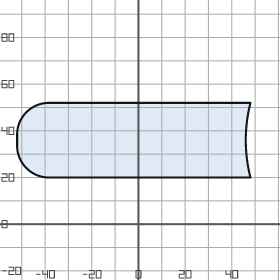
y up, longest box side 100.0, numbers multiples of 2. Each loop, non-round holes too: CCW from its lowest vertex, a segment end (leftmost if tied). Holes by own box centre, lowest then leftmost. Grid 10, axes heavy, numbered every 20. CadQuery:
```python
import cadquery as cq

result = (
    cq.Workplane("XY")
    .moveTo(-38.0, 20.0)
    .lineTo(48.0, 20.0)
    .threePointArc((46.0, 36.0), (48.0, 52.0))
    .lineTo(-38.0, 52.0)
    .threePointArc((-48.0, 48.0), (-52.0, 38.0))
    .lineTo(-52.0, 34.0)
    .threePointArc((-48.0, 24.0), (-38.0, 20.0))
    .close()
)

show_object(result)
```